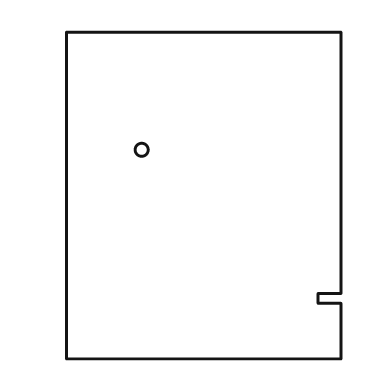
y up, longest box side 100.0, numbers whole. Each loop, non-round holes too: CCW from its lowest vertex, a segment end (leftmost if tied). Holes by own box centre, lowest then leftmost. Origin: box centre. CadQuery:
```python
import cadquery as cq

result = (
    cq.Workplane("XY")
    .moveTo(-42.0, -50.0)
    .lineTo(42.0, -50.0)
    .lineTo(42.0, -33.0)
    .lineTo(35.0, -33.0)
    .lineTo(35.0, -30.0)
    .lineTo(42.0, -30.0)
    .lineTo(42.0, 50.0)
    .lineTo(-42.0, 50.0)
    .close()
    .moveTo(-19.0, 14.0)
    .circle(2.0)
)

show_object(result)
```